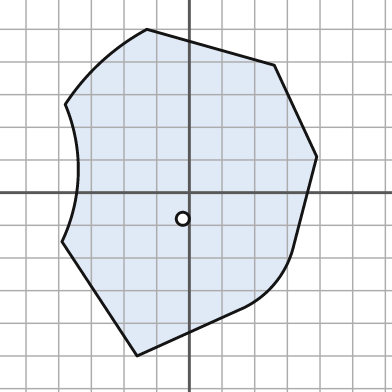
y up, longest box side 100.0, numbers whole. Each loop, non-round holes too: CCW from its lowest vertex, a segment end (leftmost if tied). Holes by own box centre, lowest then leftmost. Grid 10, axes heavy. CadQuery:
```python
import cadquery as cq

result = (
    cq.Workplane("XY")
    .moveTo(-16.0, -50.0)
    .lineTo(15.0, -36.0)
    .threePointArc((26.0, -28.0), (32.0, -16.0))
    .lineTo(39.0, 11.0)
    .lineTo(26.0, 39.0)
    .lineTo(-13.0, 50.0)
    .threePointArc((-27.0, 40.0), (-38.0, 27.0))
    .threePointArc((-34.0, 6.0), (-39.0, -15.0))
    .close()
    .moveTo(-2.0, -8.0)
    .circle(2.0)
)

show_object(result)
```